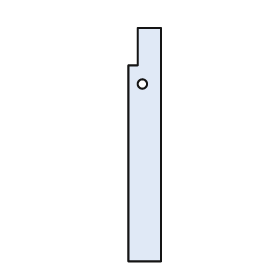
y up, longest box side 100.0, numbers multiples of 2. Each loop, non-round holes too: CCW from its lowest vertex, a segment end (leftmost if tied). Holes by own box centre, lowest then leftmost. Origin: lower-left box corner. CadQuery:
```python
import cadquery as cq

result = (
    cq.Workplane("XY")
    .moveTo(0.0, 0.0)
    .lineTo(14.0, 0.0)
    .lineTo(14.0, 100.0)
    .lineTo(4.0, 100.0)
    .lineTo(4.0, 84.0)
    .lineTo(0.0, 84.0)
    .close()
    .moveTo(6.0, 76.0)
    .circle(2.0)
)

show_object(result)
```